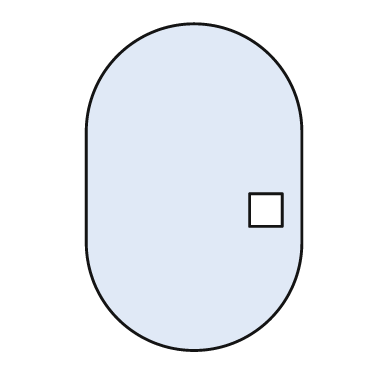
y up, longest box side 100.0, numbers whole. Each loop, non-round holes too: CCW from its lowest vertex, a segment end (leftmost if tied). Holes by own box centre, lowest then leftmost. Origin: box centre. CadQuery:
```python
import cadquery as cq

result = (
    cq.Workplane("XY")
    .moveTo(-33.0, -17.0)
    .threePointArc((0.0, -50.0), (33.0, -17.0))
    .lineTo(33.0, 17.0)
    .threePointArc((0.0, 50.0), (-33.0, 17.0))
    .close()
    .moveTo(17.0, -12.0)
    .lineTo(27.0, -12.0)
    .lineTo(27.0, -2.0)
    .lineTo(17.0, -2.0)
    .close()
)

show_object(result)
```